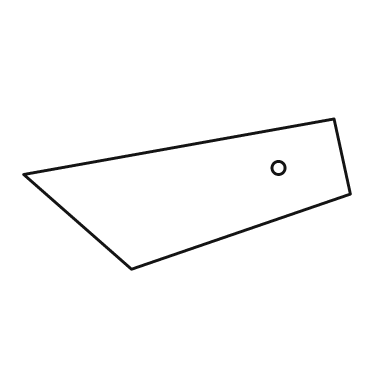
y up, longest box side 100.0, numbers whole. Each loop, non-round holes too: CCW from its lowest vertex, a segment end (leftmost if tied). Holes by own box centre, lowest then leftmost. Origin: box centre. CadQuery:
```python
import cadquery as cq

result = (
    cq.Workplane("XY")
    .moveTo(-17.0, -23.0)
    .lineTo(50.0, 0.0)
    .lineTo(45.0, 23.0)
    .lineTo(-50.0, 6.0)
    .close()
    .moveTo(28.0, 8.0)
    .circle(2.0)
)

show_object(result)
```